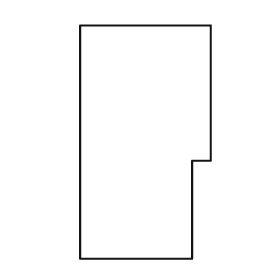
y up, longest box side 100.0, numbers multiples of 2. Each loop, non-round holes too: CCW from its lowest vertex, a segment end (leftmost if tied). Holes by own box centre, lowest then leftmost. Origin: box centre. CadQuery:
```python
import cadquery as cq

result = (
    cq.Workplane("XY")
    .moveTo(-28.0, -50.0)
    .lineTo(20.0, -50.0)
    .lineTo(20.0, -8.0)
    .lineTo(28.0, -8.0)
    .lineTo(28.0, 50.0)
    .lineTo(-28.0, 50.0)
    .close()
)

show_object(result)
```